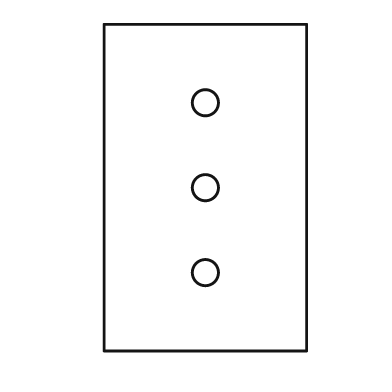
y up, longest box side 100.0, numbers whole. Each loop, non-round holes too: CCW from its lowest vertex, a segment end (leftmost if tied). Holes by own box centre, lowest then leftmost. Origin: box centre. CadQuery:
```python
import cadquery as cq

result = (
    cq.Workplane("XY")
    .moveTo(-31.0, -50.0)
    .lineTo(31.0, -50.0)
    .lineTo(31.0, 50.0)
    .lineTo(-31.0, 50.0)
    .close()
    .moveTo(0.0, -26.0)
    .circle(4.0)
    .moveTo(0.0, 0.0)
    .circle(4.0)
    .moveTo(0.0, 26.0)
    .circle(4.0)
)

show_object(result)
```